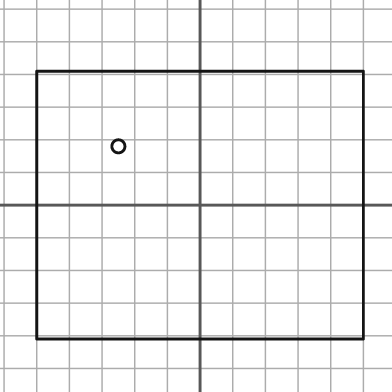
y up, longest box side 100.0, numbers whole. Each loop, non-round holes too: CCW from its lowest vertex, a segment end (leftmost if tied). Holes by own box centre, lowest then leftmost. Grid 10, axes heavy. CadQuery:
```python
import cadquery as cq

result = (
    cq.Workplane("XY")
    .moveTo(-50.0, -41.0)
    .lineTo(50.0, -41.0)
    .lineTo(50.0, 41.0)
    .lineTo(-50.0, 41.0)
    .close()
    .moveTo(-25.0, 18.0)
    .circle(2.0)
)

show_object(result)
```